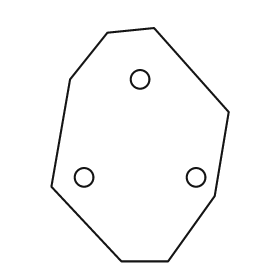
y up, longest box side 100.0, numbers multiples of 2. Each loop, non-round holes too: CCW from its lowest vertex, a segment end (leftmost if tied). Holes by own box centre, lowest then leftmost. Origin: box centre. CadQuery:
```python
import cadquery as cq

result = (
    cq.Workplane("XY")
    .moveTo(-8.0, -50.0)
    .lineTo(12.0, -50.0)
    .lineTo(32.0, -22.0)
    .lineTo(38.0, 14.0)
    .lineTo(6.0, 50.0)
    .lineTo(-14.0, 48.0)
    .lineTo(-30.0, 28.0)
    .lineTo(-38.0, -18.0)
    .close()
    .moveTo(-24.0, -14.0)
    .circle(4.0)
    .moveTo(24.0, -14.0)
    .circle(4.0)
    .moveTo(0.0, 28.0)
    .circle(4.0)
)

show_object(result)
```